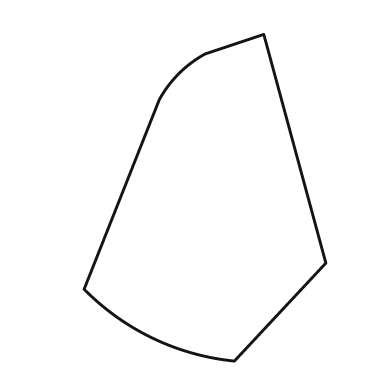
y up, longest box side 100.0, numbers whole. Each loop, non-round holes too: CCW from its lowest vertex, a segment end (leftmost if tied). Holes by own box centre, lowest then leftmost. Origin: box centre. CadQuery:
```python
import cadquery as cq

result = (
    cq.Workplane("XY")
    .moveTo(9.0, -50.0)
    .lineTo(37.0, -20.0)
    .lineTo(18.0, 50.0)
    .lineTo(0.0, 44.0)
    .threePointArc((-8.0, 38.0), (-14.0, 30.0))
    .lineTo(-37.0, -28.0)
    .threePointArc((-16.0, -43.0), (9.0, -50.0))
    .close()
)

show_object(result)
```